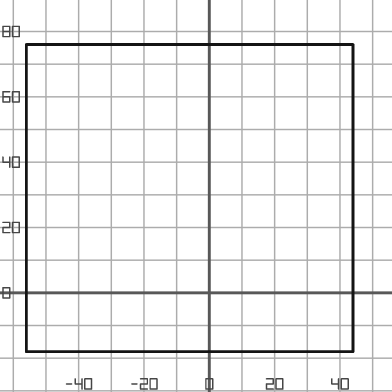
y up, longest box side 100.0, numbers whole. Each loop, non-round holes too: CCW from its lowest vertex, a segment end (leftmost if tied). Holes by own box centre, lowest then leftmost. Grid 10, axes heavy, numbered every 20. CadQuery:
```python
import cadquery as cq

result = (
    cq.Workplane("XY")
    .moveTo(-56.0, -18.0)
    .lineTo(44.0, -18.0)
    .lineTo(44.0, 76.0)
    .lineTo(-56.0, 76.0)
    .close()
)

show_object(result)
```